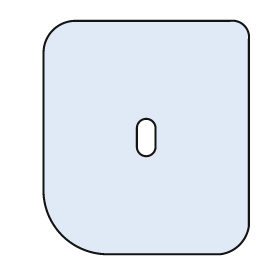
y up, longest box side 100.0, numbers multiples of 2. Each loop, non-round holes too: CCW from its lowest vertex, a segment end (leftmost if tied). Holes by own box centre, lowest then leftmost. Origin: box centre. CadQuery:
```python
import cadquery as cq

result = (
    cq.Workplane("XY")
    .moveTo(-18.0, -50.0)
    .lineTo(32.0, -50.0)
    .threePointArc((40.0, -46.0), (44.0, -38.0))
    .lineTo(44.0, 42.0)
    .threePointArc((42.0, 48.0), (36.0, 50.0))
    .lineTo(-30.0, 50.0)
    .threePointArc((-40.0, 46.0), (-44.0, 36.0))
    .lineTo(-44.0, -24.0)
    .threePointArc((-36.0, -42.0), (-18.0, -50.0))
    .close()
    .moveTo(-4.0, -4.0)
    .threePointArc((0.0, -8.0), (4.0, -4.0))
    .lineTo(4.0, 4.0)
    .threePointArc((0.0, 8.0), (-4.0, 4.0))
    .close()
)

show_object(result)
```